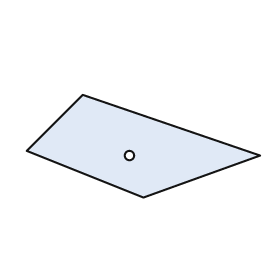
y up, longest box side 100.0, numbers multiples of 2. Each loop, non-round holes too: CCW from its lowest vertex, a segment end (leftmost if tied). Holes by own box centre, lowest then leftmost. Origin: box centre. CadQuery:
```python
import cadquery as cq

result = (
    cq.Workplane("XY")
    .moveTo(0.0, -22.0)
    .lineTo(50.0, -4.0)
    .lineTo(-26.0, 22.0)
    .lineTo(-50.0, -2.0)
    .close()
    .moveTo(-6.0, -4.0)
    .circle(2.0)
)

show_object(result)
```